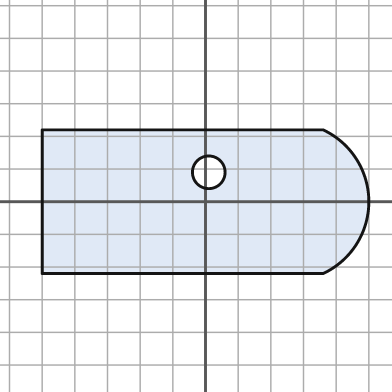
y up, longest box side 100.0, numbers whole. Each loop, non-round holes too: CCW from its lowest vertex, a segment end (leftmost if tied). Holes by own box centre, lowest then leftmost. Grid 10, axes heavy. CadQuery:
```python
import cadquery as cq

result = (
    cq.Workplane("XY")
    .moveTo(-50.0, -22.0)
    .lineTo(36.0, -22.0)
    .threePointArc((50.0, 0.0), (36.0, 22.0))
    .lineTo(-50.0, 22.0)
    .close()
    .moveTo(1.0, 9.0)
    .circle(5.0)
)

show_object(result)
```